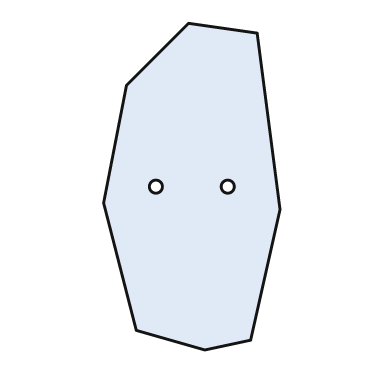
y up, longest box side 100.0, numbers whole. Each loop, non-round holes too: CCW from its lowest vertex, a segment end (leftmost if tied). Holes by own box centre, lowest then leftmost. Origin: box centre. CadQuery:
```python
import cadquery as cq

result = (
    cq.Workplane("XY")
    .moveTo(4.0, -50.0)
    .lineTo(18.0, -47.0)
    .lineTo(27.0, -7.0)
    .lineTo(20.0, 47.0)
    .lineTo(-1.0, 50.0)
    .lineTo(-20.0, 31.0)
    .lineTo(-27.0, -5.0)
    .lineTo(-17.0, -44.0)
    .close()
    .moveTo(-11.0, 0.0)
    .circle(2.0)
    .moveTo(11.0, 0.0)
    .circle(2.0)
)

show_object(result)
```